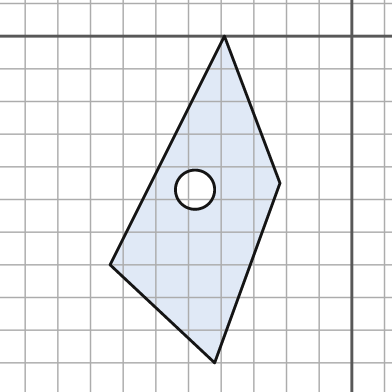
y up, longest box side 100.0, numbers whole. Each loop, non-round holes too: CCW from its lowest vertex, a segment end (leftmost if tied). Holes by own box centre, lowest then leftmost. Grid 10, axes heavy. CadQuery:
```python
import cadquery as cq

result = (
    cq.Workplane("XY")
    .moveTo(-42.0, -100.0)
    .lineTo(-22.0, -45.0)
    .lineTo(-39.0, 0.0)
    .lineTo(-74.0, -70.0)
    .close()
    .moveTo(-48.0, -47.0)
    .circle(6.0)
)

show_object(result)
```